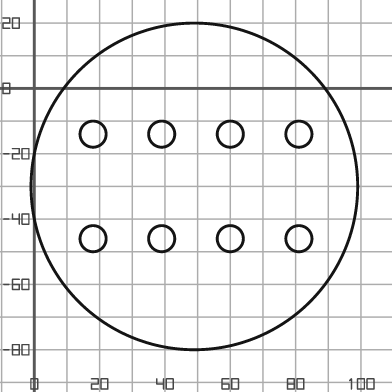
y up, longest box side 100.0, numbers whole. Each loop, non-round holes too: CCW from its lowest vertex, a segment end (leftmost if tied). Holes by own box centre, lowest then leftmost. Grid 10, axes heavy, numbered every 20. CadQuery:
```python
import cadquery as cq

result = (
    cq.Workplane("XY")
    .moveTo(49.0, -30.0)
    .circle(50.0)
    .moveTo(18.0, -46.0)
    .circle(4.0)
    .moveTo(39.0, -46.0)
    .circle(4.0)
    .moveTo(60.0, -46.0)
    .circle(4.0)
    .moveTo(81.0, -46.0)
    .circle(4.0)
    .moveTo(18.0, -14.0)
    .circle(4.0)
    .moveTo(39.0, -14.0)
    .circle(4.0)
    .moveTo(60.0, -14.0)
    .circle(4.0)
    .moveTo(81.0, -14.0)
    .circle(4.0)
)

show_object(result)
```